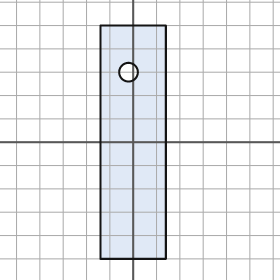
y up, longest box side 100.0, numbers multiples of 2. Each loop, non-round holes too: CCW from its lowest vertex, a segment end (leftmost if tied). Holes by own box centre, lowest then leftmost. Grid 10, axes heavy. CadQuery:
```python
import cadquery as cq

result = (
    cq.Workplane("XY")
    .moveTo(-14.0, -50.0)
    .lineTo(14.0, -50.0)
    .lineTo(14.0, 50.0)
    .lineTo(-14.0, 50.0)
    .close()
    .moveTo(-2.0, 30.0)
    .circle(4.0)
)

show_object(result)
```